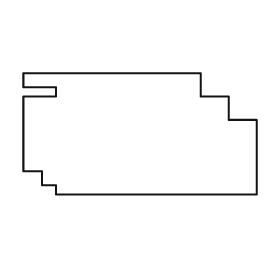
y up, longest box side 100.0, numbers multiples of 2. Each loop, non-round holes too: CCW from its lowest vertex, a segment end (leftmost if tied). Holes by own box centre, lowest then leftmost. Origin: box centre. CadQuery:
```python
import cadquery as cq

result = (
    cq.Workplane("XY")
    .moveTo(-36.0, -26.0)
    .lineTo(50.0, -26.0)
    .lineTo(50.0, 6.0)
    .lineTo(38.0, 6.0)
    .lineTo(38.0, 16.0)
    .lineTo(26.0, 16.0)
    .lineTo(26.0, 26.0)
    .lineTo(-50.0, 26.0)
    .lineTo(-50.0, 20.0)
    .lineTo(-36.0, 20.0)
    .lineTo(-36.0, 16.0)
    .lineTo(-50.0, 16.0)
    .lineTo(-50.0, -16.0)
    .lineTo(-42.0, -16.0)
    .lineTo(-42.0, -22.0)
    .lineTo(-36.0, -22.0)
    .close()
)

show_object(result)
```